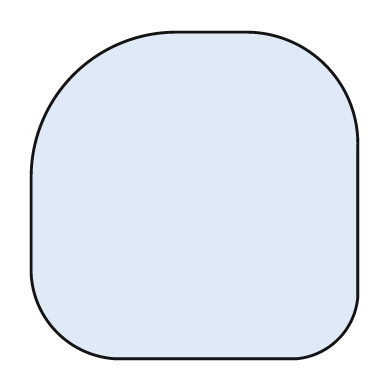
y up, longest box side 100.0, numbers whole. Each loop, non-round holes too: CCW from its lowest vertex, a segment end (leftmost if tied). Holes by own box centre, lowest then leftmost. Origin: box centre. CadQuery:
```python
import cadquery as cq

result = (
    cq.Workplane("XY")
    .moveTo(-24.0, -50.0)
    .lineTo(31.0, -50.0)
    .threePointArc((44.0, -44.0), (50.0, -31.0))
    .lineTo(50.0, 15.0)
    .threePointArc((40.0, 40.0), (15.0, 50.0))
    .lineTo(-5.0, 50.0)
    .threePointArc((-37.0, 37.0), (-50.0, 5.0))
    .lineTo(-50.0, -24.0)
    .threePointArc((-42.0, -42.0), (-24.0, -50.0))
    .close()
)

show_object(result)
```